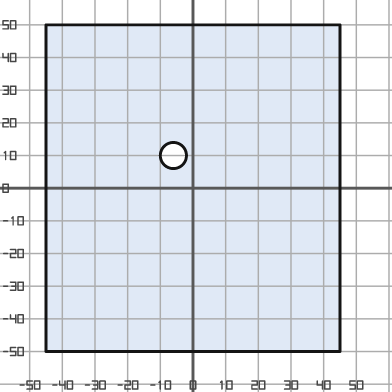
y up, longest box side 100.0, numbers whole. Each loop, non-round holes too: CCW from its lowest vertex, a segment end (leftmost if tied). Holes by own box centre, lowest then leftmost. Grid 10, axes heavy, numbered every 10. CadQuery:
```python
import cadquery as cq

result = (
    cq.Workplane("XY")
    .moveTo(-45.0, -50.0)
    .lineTo(45.0, -50.0)
    .lineTo(45.0, 50.0)
    .lineTo(-45.0, 50.0)
    .close()
    .moveTo(-6.0, 10.0)
    .circle(4.0)
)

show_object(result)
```